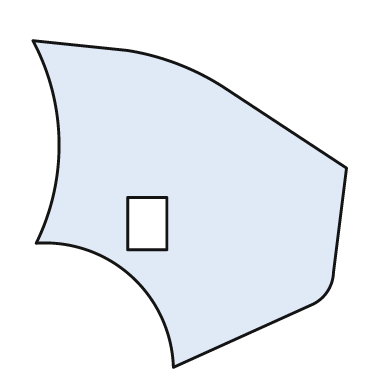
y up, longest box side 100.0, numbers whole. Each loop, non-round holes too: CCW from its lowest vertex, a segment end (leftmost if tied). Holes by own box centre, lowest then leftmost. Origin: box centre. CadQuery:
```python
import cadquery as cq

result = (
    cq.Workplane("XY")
    .moveTo(-5.0, -50.0)
    .lineTo(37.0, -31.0)
    .threePointArc((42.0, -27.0), (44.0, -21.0))
    .lineTo(48.0, 11.0)
    .lineTo(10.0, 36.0)
    .threePointArc((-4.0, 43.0), (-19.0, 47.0))
    .lineTo(-48.0, 50.0)
    .threePointArc((-40.0, 19.0), (-47.0, -12.0))
    .threePointArc((-18.0, -22.0), (-5.0, -50.0))
    .close()
    .moveTo(-19.0, -14.0)
    .lineTo(-7.0, -14.0)
    .lineTo(-7.0, 2.0)
    .lineTo(-19.0, 2.0)
    .close()
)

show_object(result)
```